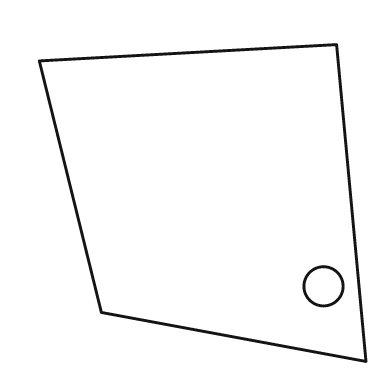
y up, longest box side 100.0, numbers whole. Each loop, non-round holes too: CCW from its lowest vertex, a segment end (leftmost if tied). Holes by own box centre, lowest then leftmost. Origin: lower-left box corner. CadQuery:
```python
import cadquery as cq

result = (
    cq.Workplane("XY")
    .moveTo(100.0, 0.0)
    .lineTo(91.0, 97.0)
    .lineTo(0.0, 92.0)
    .lineTo(19.0, 15.0)
    .close()
    .moveTo(87.0, 23.0)
    .circle(6.0)
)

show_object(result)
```